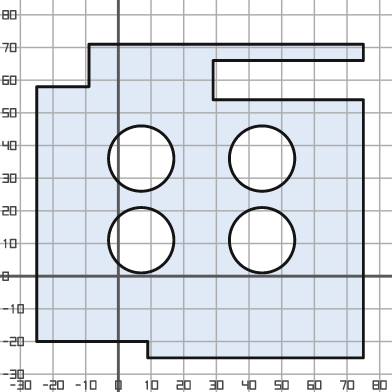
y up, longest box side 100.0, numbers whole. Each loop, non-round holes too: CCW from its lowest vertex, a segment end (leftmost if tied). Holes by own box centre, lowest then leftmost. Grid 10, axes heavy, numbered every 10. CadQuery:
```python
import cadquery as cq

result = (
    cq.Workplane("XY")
    .moveTo(9.0, -25.0)
    .lineTo(75.0, -25.0)
    .lineTo(75.0, 54.0)
    .lineTo(29.0, 54.0)
    .lineTo(29.0, 66.0)
    .lineTo(75.0, 66.0)
    .lineTo(75.0, 71.0)
    .lineTo(-9.0, 71.0)
    .lineTo(-9.0, 58.0)
    .lineTo(-25.0, 58.0)
    .lineTo(-25.0, -20.0)
    .lineTo(9.0, -20.0)
    .close()
    .moveTo(7.0, 11.0)
    .circle(10.0)
    .moveTo(44.0, 11.0)
    .circle(10.0)
    .moveTo(7.0, 36.0)
    .circle(10.0)
    .moveTo(44.0, 36.0)
    .circle(10.0)
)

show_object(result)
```